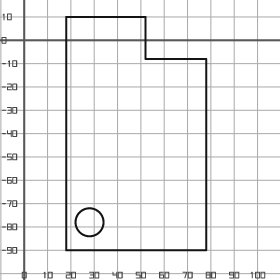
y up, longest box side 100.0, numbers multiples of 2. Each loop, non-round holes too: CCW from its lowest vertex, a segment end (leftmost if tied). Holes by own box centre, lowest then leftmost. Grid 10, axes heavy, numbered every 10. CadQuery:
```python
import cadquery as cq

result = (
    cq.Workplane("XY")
    .moveTo(18.0, -90.0)
    .lineTo(78.0, -90.0)
    .lineTo(78.0, -8.0)
    .lineTo(52.0, -8.0)
    .lineTo(52.0, 10.0)
    .lineTo(18.0, 10.0)
    .close()
    .moveTo(28.0, -78.0)
    .circle(6.0)
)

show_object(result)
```